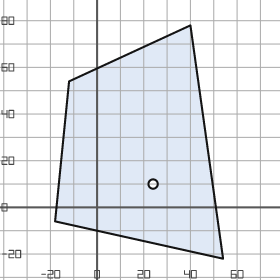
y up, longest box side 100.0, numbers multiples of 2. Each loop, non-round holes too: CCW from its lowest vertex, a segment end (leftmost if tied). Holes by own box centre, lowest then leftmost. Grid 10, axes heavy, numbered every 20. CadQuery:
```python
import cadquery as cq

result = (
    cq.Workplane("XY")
    .moveTo(54.0, -22.0)
    .lineTo(40.0, 78.0)
    .lineTo(-12.0, 54.0)
    .lineTo(-18.0, -6.0)
    .close()
    .moveTo(24.0, 10.0)
    .circle(2.0)
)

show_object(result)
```